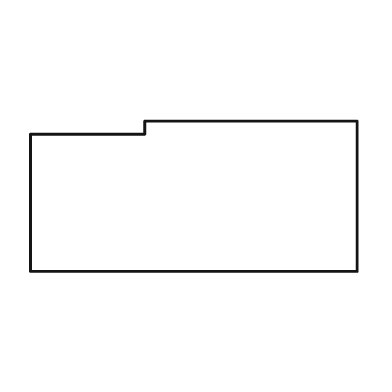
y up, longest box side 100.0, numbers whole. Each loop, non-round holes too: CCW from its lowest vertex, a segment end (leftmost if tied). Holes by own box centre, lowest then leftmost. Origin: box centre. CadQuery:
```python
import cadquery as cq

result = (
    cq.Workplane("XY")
    .moveTo(-50.0, -23.0)
    .lineTo(50.0, -23.0)
    .lineTo(50.0, 23.0)
    .lineTo(-15.0, 23.0)
    .lineTo(-15.0, 19.0)
    .lineTo(-50.0, 19.0)
    .close()
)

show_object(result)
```